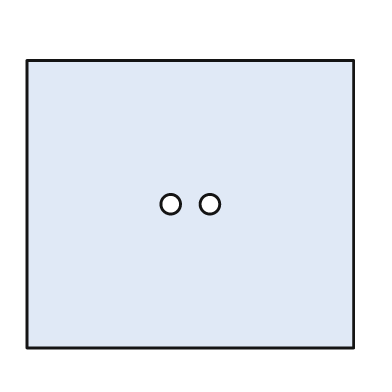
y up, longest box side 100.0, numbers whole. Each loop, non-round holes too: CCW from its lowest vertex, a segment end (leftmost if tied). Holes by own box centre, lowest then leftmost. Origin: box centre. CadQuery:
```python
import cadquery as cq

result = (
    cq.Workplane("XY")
    .moveTo(-50.0, -44.0)
    .lineTo(50.0, -44.0)
    .lineTo(50.0, 44.0)
    .lineTo(-50.0, 44.0)
    .close()
    .moveTo(-6.0, 0.0)
    .circle(3.0)
    .moveTo(6.0, 0.0)
    .circle(3.0)
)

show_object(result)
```